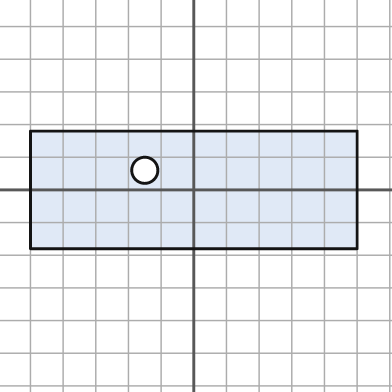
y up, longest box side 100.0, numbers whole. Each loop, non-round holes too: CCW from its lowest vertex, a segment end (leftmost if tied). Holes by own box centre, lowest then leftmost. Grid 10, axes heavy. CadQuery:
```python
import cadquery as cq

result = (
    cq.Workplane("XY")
    .moveTo(-50.0, -18.0)
    .lineTo(50.0, -18.0)
    .lineTo(50.0, 18.0)
    .lineTo(-50.0, 18.0)
    .close()
    .moveTo(-15.0, 6.0)
    .circle(4.0)
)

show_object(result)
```